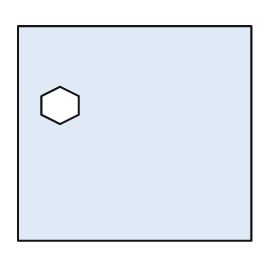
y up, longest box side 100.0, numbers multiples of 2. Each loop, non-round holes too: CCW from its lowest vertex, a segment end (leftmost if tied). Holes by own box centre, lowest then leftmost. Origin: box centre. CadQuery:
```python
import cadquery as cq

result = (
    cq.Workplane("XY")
    .moveTo(-50.0, -46.0)
    .lineTo(50.0, -46.0)
    .lineTo(50.0, 46.0)
    .lineTo(-50.0, 46.0)
    .close()
    .moveTo(-32.0, 4.0)
    .lineTo(-24.0, 8.0)
    .lineTo(-24.0, 16.0)
    .lineTo(-32.0, 20.0)
    .lineTo(-40.0, 16.0)
    .lineTo(-40.0, 8.0)
    .close()
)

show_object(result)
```